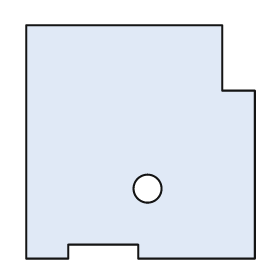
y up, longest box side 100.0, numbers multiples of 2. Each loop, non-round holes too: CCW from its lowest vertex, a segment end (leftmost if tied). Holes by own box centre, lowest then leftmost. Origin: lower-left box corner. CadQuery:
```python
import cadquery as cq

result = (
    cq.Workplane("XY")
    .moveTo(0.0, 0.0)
    .lineTo(18.0, 0.0)
    .lineTo(18.0, 6.0)
    .lineTo(48.0, 6.0)
    .lineTo(48.0, 0.0)
    .lineTo(98.0, 0.0)
    .lineTo(98.0, 72.0)
    .lineTo(84.0, 72.0)
    .lineTo(84.0, 100.0)
    .lineTo(0.0, 100.0)
    .close()
    .moveTo(52.0, 30.0)
    .circle(6.0)
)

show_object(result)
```